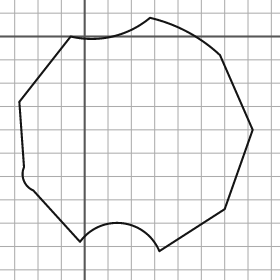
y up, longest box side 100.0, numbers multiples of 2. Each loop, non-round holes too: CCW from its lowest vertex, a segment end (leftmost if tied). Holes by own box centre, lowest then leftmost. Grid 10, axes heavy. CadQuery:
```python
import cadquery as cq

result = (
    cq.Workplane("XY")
    .moveTo(32.0, -92.0)
    .lineTo(60.0, -74.0)
    .lineTo(72.0, -40.0)
    .lineTo(58.0, -8.0)
    .threePointArc((44.0, 2.0), (28.0, 8.0))
    .threePointArc((12.0, 0.0), (-6.0, 0.0))
    .lineTo(-28.0, -28.0)
    .lineTo(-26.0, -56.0)
    .threePointArc((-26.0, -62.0), (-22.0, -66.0))
    .lineTo(-2.0, -88.0)
    .threePointArc((16.0, -80.0), (32.0, -92.0))
    .close()
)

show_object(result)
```